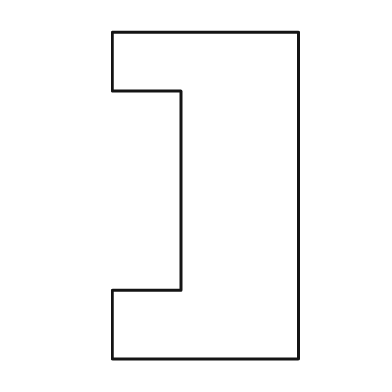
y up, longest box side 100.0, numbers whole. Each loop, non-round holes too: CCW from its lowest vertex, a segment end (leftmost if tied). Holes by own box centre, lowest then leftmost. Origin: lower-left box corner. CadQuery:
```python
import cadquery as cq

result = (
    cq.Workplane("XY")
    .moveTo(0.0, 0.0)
    .lineTo(57.0, 0.0)
    .lineTo(57.0, 100.0)
    .lineTo(0.0, 100.0)
    .lineTo(0.0, 82.0)
    .lineTo(21.0, 82.0)
    .lineTo(21.0, 21.0)
    .lineTo(0.0, 21.0)
    .close()
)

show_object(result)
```